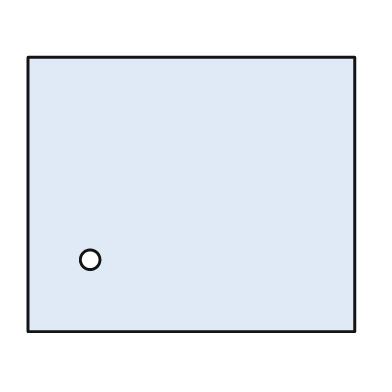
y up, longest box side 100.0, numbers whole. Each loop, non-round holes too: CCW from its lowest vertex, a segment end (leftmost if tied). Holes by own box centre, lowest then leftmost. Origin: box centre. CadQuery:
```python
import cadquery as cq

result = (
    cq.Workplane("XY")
    .moveTo(-50.0, -42.0)
    .lineTo(50.0, -42.0)
    .lineTo(50.0, 42.0)
    .lineTo(-50.0, 42.0)
    .close()
    .moveTo(-31.0, -20.0)
    .circle(3.0)
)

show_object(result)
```